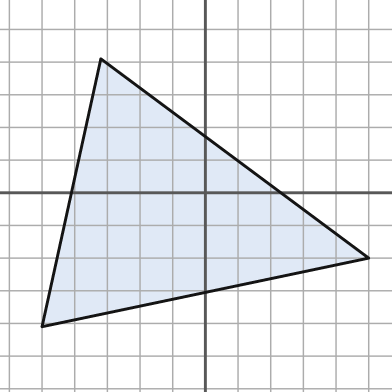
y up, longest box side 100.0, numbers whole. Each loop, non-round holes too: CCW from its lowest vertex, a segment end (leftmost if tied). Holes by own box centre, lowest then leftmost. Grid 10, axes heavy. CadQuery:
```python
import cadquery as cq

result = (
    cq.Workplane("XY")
    .moveTo(-50.0, -41.0)
    .lineTo(50.0, -20.0)
    .lineTo(-32.0, 41.0)
    .close()
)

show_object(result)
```